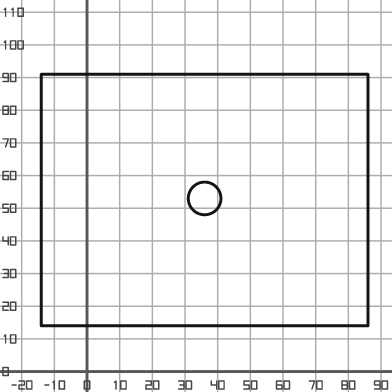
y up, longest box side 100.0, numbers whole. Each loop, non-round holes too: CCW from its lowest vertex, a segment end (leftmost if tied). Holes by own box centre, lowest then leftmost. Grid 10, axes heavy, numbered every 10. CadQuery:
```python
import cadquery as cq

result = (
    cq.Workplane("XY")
    .moveTo(-14.0, 14.0)
    .lineTo(86.0, 14.0)
    .lineTo(86.0, 91.0)
    .lineTo(-14.0, 91.0)
    .close()
    .moveTo(36.0, 53.0)
    .circle(5.0)
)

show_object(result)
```